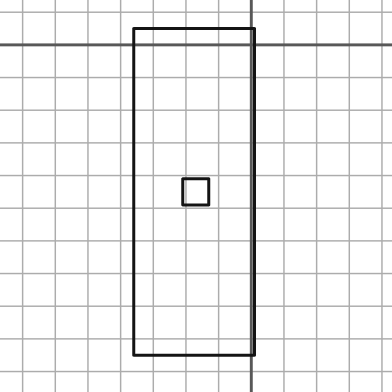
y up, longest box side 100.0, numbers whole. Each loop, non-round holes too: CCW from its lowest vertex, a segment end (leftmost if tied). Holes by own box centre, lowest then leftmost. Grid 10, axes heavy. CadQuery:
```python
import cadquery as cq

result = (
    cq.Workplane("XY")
    .moveTo(-36.0, -95.0)
    .lineTo(1.0, -95.0)
    .lineTo(1.0, 5.0)
    .lineTo(-36.0, 5.0)
    .close()
    .moveTo(-21.0, -49.0)
    .lineTo(-13.0, -49.0)
    .lineTo(-13.0, -41.0)
    .lineTo(-21.0, -41.0)
    .close()
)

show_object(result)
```